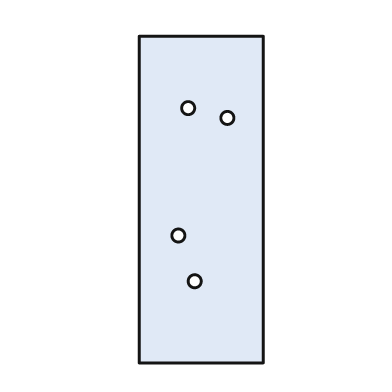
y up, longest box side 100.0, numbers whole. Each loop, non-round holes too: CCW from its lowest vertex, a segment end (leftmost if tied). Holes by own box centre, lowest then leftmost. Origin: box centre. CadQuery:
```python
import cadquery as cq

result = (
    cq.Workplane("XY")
    .moveTo(-19.0, -50.0)
    .lineTo(19.0, -50.0)
    .lineTo(19.0, 50.0)
    .lineTo(-19.0, 50.0)
    .close()
    .moveTo(-2.0, -25.0)
    .circle(2.0)
    .moveTo(-7.0, -11.0)
    .circle(2.0)
    .moveTo(8.0, 25.0)
    .circle(2.0)
    .moveTo(-4.0, 28.0)
    .circle(2.0)
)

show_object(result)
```